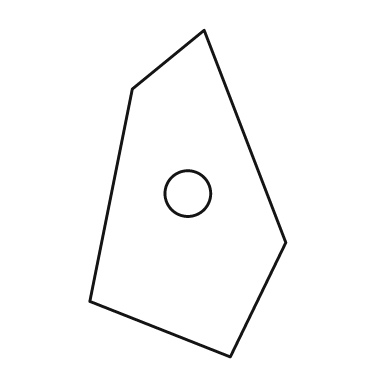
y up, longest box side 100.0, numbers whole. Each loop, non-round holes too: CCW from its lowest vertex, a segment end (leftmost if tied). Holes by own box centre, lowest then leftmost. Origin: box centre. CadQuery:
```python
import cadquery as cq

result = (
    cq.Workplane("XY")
    .moveTo(13.0, -50.0)
    .lineTo(30.0, -15.0)
    .lineTo(5.0, 50.0)
    .lineTo(-17.0, 32.0)
    .lineTo(-30.0, -33.0)
    .close()
    .moveTo(0.0, 0.0)
    .circle(7.0)
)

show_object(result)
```